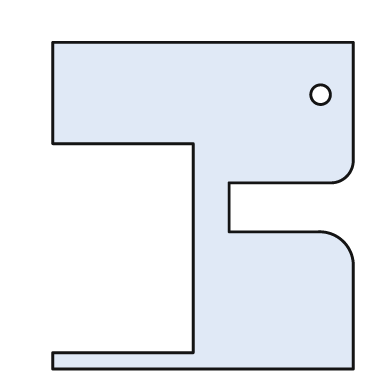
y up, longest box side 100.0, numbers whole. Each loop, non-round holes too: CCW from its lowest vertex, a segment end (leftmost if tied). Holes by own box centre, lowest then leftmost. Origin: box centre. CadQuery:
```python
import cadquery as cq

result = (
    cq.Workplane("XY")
    .moveTo(-46.0, -50.0)
    .lineTo(46.0, -50.0)
    .lineTo(46.0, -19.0)
    .threePointArc((43.0, -11.0), (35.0, -8.0))
    .lineTo(8.0, -8.0)
    .lineTo(8.0, 7.0)
    .lineTo(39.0, 7.0)
    .threePointArc((44.0, 9.0), (46.0, 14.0))
    .lineTo(46.0, 50.0)
    .lineTo(-46.0, 50.0)
    .lineTo(-46.0, 19.0)
    .lineTo(-3.0, 19.0)
    .lineTo(-3.0, -45.0)
    .lineTo(-46.0, -45.0)
    .close()
    .moveTo(36.0, 34.0)
    .circle(3.0)
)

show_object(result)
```